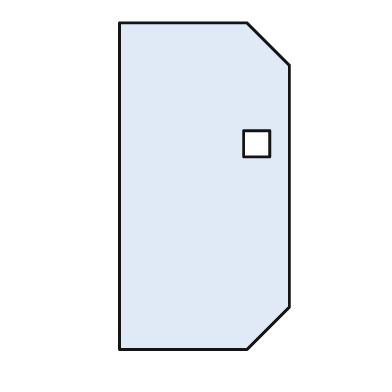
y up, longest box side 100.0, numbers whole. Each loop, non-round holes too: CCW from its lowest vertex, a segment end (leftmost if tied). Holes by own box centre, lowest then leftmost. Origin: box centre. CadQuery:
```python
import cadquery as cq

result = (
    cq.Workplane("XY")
    .moveTo(-26.0, -50.0)
    .lineTo(13.0, -50.0)
    .lineTo(26.0, -37.0)
    .lineTo(26.0, 37.0)
    .lineTo(13.0, 50.0)
    .lineTo(-26.0, 50.0)
    .close()
    .moveTo(12.0, 9.0)
    .lineTo(20.0, 9.0)
    .lineTo(20.0, 17.0)
    .lineTo(12.0, 17.0)
    .close()
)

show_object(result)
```